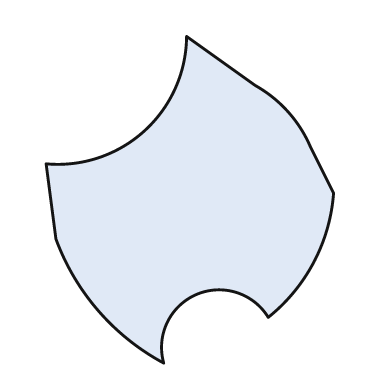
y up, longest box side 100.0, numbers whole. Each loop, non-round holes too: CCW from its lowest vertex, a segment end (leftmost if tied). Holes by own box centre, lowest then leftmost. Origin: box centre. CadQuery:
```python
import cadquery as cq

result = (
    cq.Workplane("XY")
    .moveTo(-8.0, -50.0)
    .threePointArc((2.0, -29.0), (24.0, -36.0))
    .threePointArc((38.0, -19.0), (44.0, 2.0))
    .lineTo(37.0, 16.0)
    .threePointArc((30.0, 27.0), (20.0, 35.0))
    .lineTo(-1.0, 50.0)
    .threePointArc((-14.0, 21.0), (-44.0, 11.0))
    .lineTo(-41.0, -12.0)
    .threePointArc((-28.0, -34.0), (-8.0, -50.0))
    .close()
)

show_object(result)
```